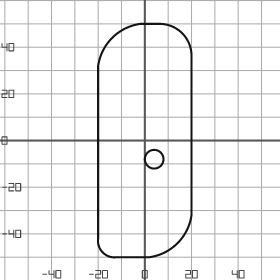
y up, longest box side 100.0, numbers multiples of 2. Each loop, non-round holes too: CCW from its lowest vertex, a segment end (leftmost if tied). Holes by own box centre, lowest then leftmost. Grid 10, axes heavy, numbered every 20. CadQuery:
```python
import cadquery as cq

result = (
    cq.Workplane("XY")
    .moveTo(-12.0, -50.0)
    .lineTo(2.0, -50.0)
    .threePointArc((14.0, -44.0), (20.0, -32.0))
    .lineTo(20.0, 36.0)
    .threePointArc((16.0, 46.0), (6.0, 50.0))
    .lineTo(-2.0, 50.0)
    .threePointArc((-14.0, 44.0), (-20.0, 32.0))
    .lineTo(-20.0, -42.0)
    .threePointArc((-18.0, -48.0), (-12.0, -50.0))
    .close()
    .moveTo(4.0, -8.0)
    .circle(4.0)
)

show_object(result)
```